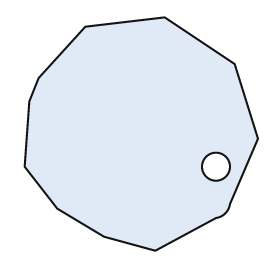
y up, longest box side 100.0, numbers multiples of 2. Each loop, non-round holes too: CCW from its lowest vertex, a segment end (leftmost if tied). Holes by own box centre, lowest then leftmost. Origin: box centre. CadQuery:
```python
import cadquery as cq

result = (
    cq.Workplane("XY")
    .moveTo(6.0, -50.0)
    .lineTo(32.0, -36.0)
    .threePointArc((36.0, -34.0), (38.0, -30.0))
    .lineTo(50.0, -2.0)
    .lineTo(40.0, 30.0)
    .lineTo(10.0, 50.0)
    .lineTo(-24.0, 46.0)
    .lineTo(-44.0, 24.0)
    .lineTo(-48.0, 14.0)
    .lineTo(-50.0, -14.0)
    .lineTo(-36.0, -32.0)
    .lineTo(-16.0, -44.0)
    .close()
    .moveTo(32.0, -14.0)
    .circle(6.0)
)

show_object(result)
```